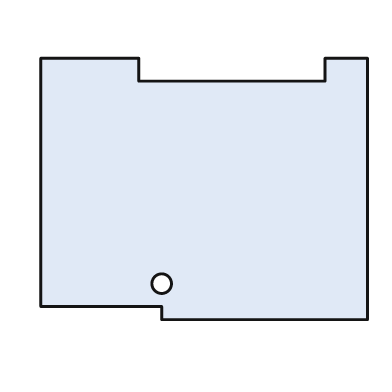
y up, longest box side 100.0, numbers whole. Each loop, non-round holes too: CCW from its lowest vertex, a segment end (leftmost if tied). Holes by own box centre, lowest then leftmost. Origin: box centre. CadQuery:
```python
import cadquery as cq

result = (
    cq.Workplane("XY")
    .moveTo(-13.0, -40.0)
    .lineTo(50.0, -40.0)
    .lineTo(50.0, 40.0)
    .lineTo(37.0, 40.0)
    .lineTo(37.0, 33.0)
    .lineTo(-20.0, 33.0)
    .lineTo(-20.0, 40.0)
    .lineTo(-50.0, 40.0)
    .lineTo(-50.0, -36.0)
    .lineTo(-13.0, -36.0)
    .close()
    .moveTo(-13.0, -29.0)
    .circle(3.0)
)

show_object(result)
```